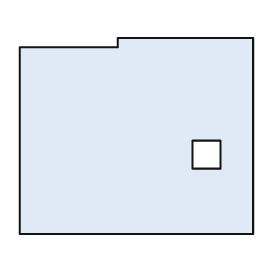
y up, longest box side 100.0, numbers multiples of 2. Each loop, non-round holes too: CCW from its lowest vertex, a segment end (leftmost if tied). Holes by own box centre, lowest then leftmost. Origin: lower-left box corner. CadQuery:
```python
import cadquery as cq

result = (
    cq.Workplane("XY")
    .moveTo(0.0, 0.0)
    .lineTo(100.0, 0.0)
    .lineTo(100.0, 84.0)
    .lineTo(42.0, 84.0)
    .lineTo(42.0, 80.0)
    .lineTo(0.0, 80.0)
    .close()
    .moveTo(74.0, 28.0)
    .lineTo(86.0, 28.0)
    .lineTo(86.0, 40.0)
    .lineTo(74.0, 40.0)
    .close()
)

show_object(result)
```